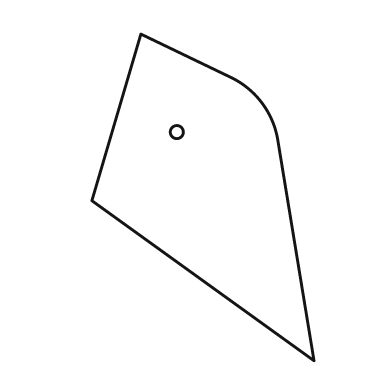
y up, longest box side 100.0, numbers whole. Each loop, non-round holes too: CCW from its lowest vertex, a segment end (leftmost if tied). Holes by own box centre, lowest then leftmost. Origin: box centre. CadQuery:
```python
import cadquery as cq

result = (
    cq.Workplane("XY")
    .moveTo(34.0, -50.0)
    .lineTo(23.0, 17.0)
    .threePointArc((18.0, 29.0), (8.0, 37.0))
    .lineTo(-19.0, 50.0)
    .lineTo(-34.0, -1.0)
    .close()
    .moveTo(-8.0, 20.0)
    .circle(2.0)
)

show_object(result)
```